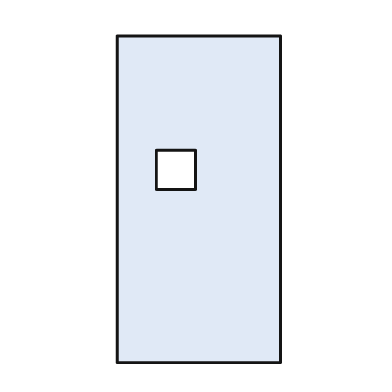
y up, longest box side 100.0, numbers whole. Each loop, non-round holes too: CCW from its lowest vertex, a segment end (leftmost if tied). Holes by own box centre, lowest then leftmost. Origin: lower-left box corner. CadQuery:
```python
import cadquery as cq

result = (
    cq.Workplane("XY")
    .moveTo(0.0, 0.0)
    .lineTo(50.0, 0.0)
    .lineTo(50.0, 100.0)
    .lineTo(0.0, 100.0)
    .close()
    .moveTo(12.0, 53.0)
    .lineTo(24.0, 53.0)
    .lineTo(24.0, 65.0)
    .lineTo(12.0, 65.0)
    .close()
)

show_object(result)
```